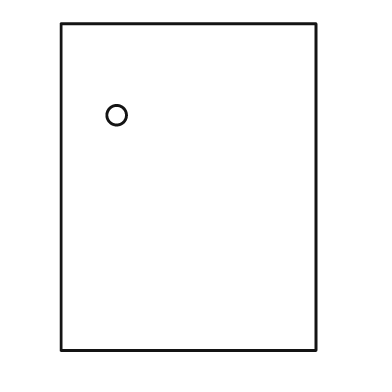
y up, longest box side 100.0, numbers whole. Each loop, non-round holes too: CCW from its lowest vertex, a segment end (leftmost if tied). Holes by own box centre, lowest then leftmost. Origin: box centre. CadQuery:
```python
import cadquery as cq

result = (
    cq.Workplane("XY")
    .moveTo(-39.0, -50.0)
    .lineTo(39.0, -50.0)
    .lineTo(39.0, 50.0)
    .lineTo(-39.0, 50.0)
    .close()
    .moveTo(-22.0, 22.0)
    .circle(3.0)
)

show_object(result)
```